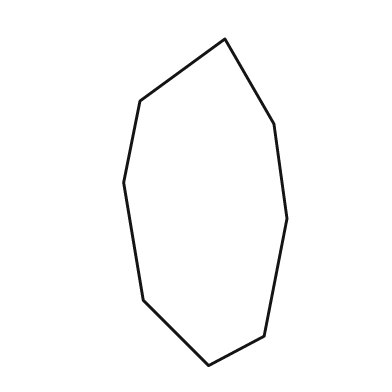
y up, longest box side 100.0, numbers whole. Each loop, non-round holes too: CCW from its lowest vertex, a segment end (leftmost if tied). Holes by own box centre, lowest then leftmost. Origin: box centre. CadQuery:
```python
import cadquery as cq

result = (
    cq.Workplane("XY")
    .moveTo(1.0, -50.0)
    .lineTo(18.0, -41.0)
    .lineTo(25.0, -5.0)
    .lineTo(21.0, 24.0)
    .lineTo(6.0, 50.0)
    .lineTo(-20.0, 31.0)
    .lineTo(-25.0, 6.0)
    .lineTo(-19.0, -30.0)
    .close()
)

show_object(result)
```